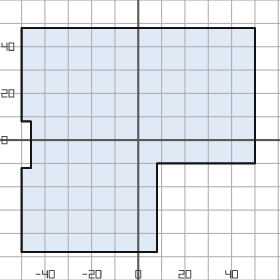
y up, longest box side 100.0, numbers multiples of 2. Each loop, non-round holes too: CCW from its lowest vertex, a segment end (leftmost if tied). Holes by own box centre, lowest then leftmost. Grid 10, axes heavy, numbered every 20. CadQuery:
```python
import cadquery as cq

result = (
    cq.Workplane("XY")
    .moveTo(-50.0, -48.0)
    .lineTo(8.0, -48.0)
    .lineTo(8.0, -10.0)
    .lineTo(50.0, -10.0)
    .lineTo(50.0, 48.0)
    .lineTo(-50.0, 48.0)
    .lineTo(-50.0, 8.0)
    .lineTo(-46.0, 8.0)
    .lineTo(-46.0, -12.0)
    .lineTo(-50.0, -12.0)
    .close()
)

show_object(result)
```